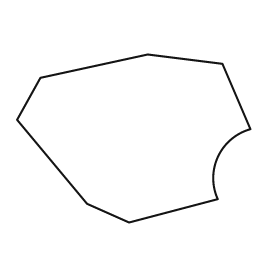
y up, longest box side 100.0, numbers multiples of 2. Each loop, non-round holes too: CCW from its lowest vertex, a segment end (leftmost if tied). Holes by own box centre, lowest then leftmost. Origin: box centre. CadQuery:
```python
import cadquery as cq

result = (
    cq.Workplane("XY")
    .moveTo(-2.0, -36.0)
    .lineTo(36.0, -26.0)
    .threePointArc((36.0, -8.0), (50.0, 4.0))
    .lineTo(38.0, 32.0)
    .lineTo(6.0, 36.0)
    .lineTo(-40.0, 26.0)
    .lineTo(-50.0, 8.0)
    .lineTo(-20.0, -28.0)
    .close()
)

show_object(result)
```